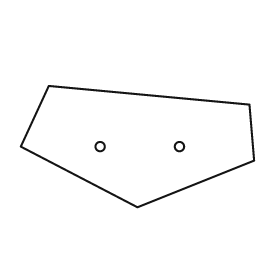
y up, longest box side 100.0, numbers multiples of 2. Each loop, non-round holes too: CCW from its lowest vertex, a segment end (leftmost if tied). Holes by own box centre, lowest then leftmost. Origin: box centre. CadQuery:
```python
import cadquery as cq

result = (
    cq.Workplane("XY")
    .moveTo(0.0, -26.0)
    .lineTo(50.0, -6.0)
    .lineTo(48.0, 18.0)
    .lineTo(-38.0, 26.0)
    .lineTo(-50.0, 0.0)
    .close()
    .moveTo(-16.0, 0.0)
    .circle(2.0)
    .moveTo(18.0, 0.0)
    .circle(2.0)
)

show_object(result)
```